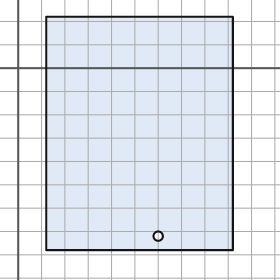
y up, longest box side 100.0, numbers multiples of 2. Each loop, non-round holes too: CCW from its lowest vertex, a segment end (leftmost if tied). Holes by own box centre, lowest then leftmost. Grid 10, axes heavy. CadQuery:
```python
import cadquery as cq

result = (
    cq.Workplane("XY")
    .moveTo(12.0, -78.0)
    .lineTo(92.0, -78.0)
    .lineTo(92.0, 22.0)
    .lineTo(12.0, 22.0)
    .close()
    .moveTo(60.0, -72.0)
    .circle(2.0)
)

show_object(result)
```